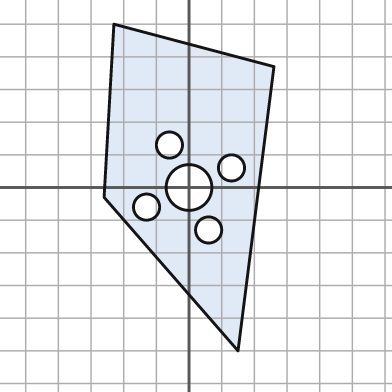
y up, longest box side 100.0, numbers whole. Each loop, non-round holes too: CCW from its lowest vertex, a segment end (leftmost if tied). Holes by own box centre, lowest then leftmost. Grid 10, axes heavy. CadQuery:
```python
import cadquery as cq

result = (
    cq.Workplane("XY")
    .moveTo(15.0, -50.0)
    .lineTo(26.0, 37.0)
    .lineTo(-23.0, 50.0)
    .lineTo(-26.0, -3.0)
    .close()
    .moveTo(6.0, -13.0)
    .circle(4.0)
    .moveTo(-13.0, -6.0)
    .circle(4.0)
    .moveTo(0.0, 0.0)
    .circle(7.0)
    .moveTo(13.0, 6.0)
    .circle(4.0)
    .moveTo(-6.0, 13.0)
    .circle(4.0)
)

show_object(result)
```